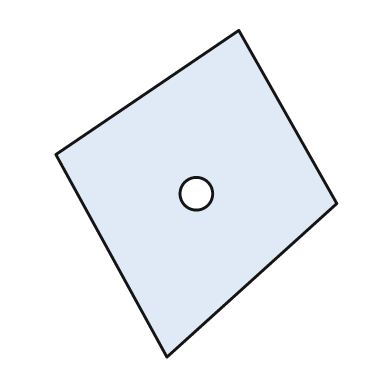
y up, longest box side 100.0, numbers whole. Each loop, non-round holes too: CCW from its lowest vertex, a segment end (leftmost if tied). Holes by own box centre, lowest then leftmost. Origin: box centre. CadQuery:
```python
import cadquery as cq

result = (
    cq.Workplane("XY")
    .moveTo(-9.0, -50.0)
    .lineTo(43.0, -3.0)
    .lineTo(13.0, 50.0)
    .lineTo(-43.0, 12.0)
    .close()
    .moveTo(0.0, 0.0)
    .circle(5.0)
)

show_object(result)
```